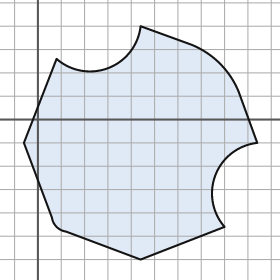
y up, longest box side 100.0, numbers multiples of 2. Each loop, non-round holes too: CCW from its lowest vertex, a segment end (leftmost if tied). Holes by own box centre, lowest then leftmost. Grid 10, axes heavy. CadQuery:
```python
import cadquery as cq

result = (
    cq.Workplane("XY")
    .moveTo(44.0, -60.0)
    .lineTo(80.0, -46.0)
    .threePointArc((76.0, -24.0), (94.0, -10.0))
    .lineTo(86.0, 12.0)
    .threePointArc((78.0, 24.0), (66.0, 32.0))
    .lineTo(44.0, 40.0)
    .threePointArc((30.0, 22.0), (8.0, 26.0))
    .lineTo(-6.0, -10.0)
    .lineTo(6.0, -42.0)
    .threePointArc((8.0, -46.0), (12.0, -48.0))
    .close()
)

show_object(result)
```